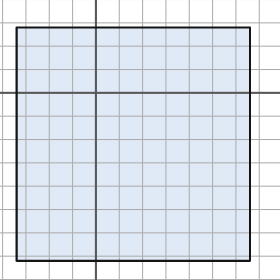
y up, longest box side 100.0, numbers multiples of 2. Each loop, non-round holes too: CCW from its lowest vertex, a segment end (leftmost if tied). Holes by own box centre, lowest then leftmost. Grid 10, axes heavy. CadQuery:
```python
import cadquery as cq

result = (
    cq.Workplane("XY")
    .moveTo(-34.0, -72.0)
    .lineTo(66.0, -72.0)
    .lineTo(66.0, 28.0)
    .lineTo(-34.0, 28.0)
    .close()
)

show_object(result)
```